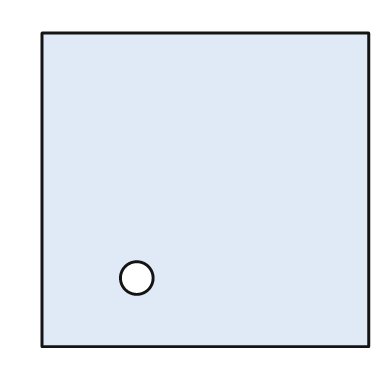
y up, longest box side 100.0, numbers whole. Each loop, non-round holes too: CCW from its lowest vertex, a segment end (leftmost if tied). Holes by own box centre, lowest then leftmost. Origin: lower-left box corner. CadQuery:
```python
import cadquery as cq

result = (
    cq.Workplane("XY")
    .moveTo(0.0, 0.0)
    .lineTo(100.0, 0.0)
    .lineTo(100.0, 96.0)
    .lineTo(0.0, 96.0)
    .close()
    .moveTo(29.0, 21.0)
    .circle(5.0)
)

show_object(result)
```